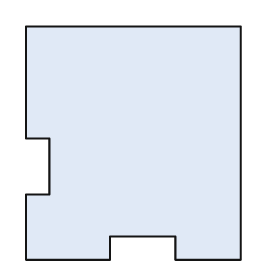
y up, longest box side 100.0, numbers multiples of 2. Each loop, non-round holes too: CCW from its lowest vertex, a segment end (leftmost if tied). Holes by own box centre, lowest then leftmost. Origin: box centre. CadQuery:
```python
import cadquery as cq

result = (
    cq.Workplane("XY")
    .moveTo(-46.0, -50.0)
    .lineTo(-10.0, -50.0)
    .lineTo(-10.0, -40.0)
    .lineTo(18.0, -40.0)
    .lineTo(18.0, -50.0)
    .lineTo(46.0, -50.0)
    .lineTo(46.0, 50.0)
    .lineTo(-46.0, 50.0)
    .lineTo(-46.0, 2.0)
    .lineTo(-36.0, 2.0)
    .lineTo(-36.0, -22.0)
    .lineTo(-46.0, -22.0)
    .close()
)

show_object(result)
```